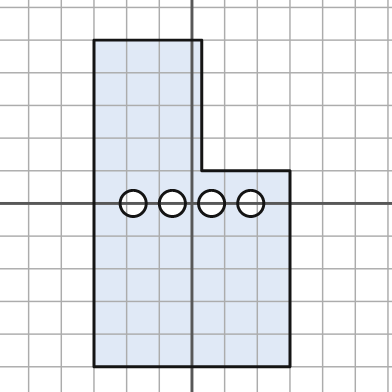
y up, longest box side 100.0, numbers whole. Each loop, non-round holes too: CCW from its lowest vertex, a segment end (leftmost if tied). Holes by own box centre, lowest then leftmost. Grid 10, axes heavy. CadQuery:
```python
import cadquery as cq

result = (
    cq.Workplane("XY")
    .moveTo(-30.0, -50.0)
    .lineTo(30.0, -50.0)
    .lineTo(30.0, 10.0)
    .lineTo(3.0, 10.0)
    .lineTo(3.0, 50.0)
    .lineTo(-30.0, 50.0)
    .close()
    .moveTo(-18.0, 0.0)
    .circle(4.0)
    .moveTo(-6.0, 0.0)
    .circle(4.0)
    .moveTo(6.0, 0.0)
    .circle(4.0)
    .moveTo(18.0, 0.0)
    .circle(4.0)
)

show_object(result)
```